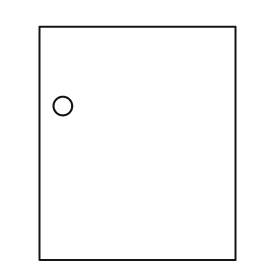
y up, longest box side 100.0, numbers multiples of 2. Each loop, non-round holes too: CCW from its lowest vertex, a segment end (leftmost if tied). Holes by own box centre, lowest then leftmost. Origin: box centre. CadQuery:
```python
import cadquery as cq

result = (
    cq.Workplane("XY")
    .moveTo(-42.0, -50.0)
    .lineTo(42.0, -50.0)
    .lineTo(42.0, 50.0)
    .lineTo(-42.0, 50.0)
    .close()
    .moveTo(-32.0, 16.0)
    .circle(4.0)
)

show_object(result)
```